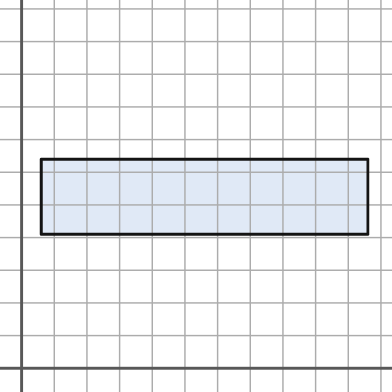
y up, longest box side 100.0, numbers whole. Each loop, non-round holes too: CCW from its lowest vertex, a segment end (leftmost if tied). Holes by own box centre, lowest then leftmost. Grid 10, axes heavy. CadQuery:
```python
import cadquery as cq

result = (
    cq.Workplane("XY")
    .moveTo(6.0, 41.0)
    .lineTo(106.0, 41.0)
    .lineTo(106.0, 64.0)
    .lineTo(6.0, 64.0)
    .close()
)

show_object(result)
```